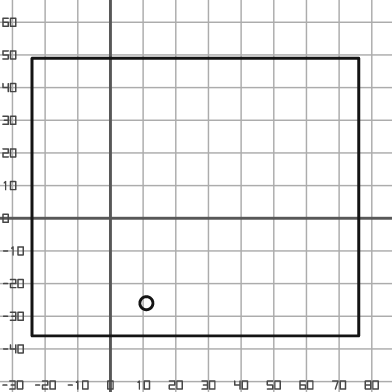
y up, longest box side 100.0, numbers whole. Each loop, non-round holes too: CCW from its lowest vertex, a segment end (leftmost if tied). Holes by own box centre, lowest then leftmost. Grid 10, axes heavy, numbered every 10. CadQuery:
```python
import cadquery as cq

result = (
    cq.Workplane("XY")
    .moveTo(-24.0, -36.0)
    .lineTo(76.0, -36.0)
    .lineTo(76.0, 49.0)
    .lineTo(-24.0, 49.0)
    .close()
    .moveTo(11.0, -26.0)
    .circle(2.0)
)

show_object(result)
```